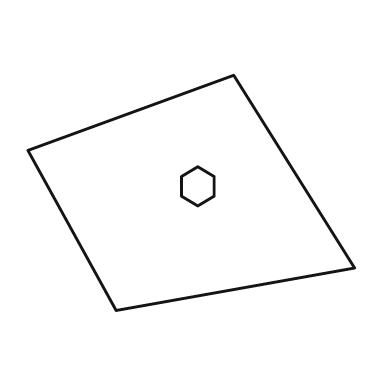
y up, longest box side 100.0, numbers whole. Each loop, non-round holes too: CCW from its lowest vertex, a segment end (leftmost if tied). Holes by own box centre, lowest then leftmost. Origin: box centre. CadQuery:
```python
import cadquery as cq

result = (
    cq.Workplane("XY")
    .moveTo(-23.0, -36.0)
    .lineTo(50.0, -23.0)
    .lineTo(13.0, 36.0)
    .lineTo(-50.0, 13.0)
    .close()
    .moveTo(2.0, -4.0)
    .lineTo(7.0, -1.0)
    .lineTo(7.0, 5.0)
    .lineTo(2.0, 8.0)
    .lineTo(-3.0, 5.0)
    .lineTo(-3.0, -1.0)
    .close()
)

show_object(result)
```